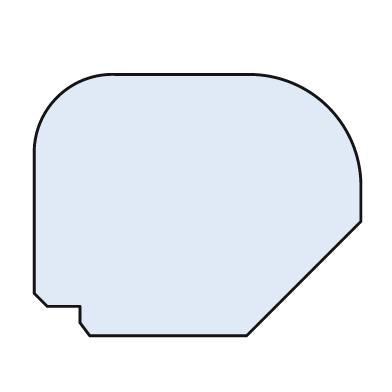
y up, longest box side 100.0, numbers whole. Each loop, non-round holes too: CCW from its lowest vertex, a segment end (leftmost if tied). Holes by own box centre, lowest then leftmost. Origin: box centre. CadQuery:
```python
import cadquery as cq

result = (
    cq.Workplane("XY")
    .moveTo(-33.0, -40.0)
    .lineTo(15.0, -40.0)
    .lineTo(50.0, -5.0)
    .lineTo(50.0, 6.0)
    .threePointArc((40.0, 30.0), (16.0, 40.0))
    .lineTo(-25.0, 40.0)
    .threePointArc((-43.0, 33.0), (-50.0, 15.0))
    .lineTo(-50.0, -27.0)
    .lineTo(-46.0, -31.0)
    .lineTo(-36.0, -31.0)
    .lineTo(-36.0, -36.0)
    .close()
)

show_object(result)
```